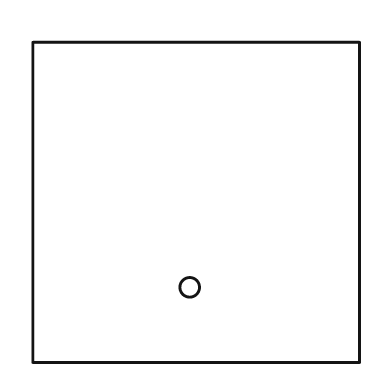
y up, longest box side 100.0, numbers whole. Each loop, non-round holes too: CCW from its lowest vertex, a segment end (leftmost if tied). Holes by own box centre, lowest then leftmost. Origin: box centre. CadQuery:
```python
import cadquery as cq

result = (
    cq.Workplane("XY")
    .moveTo(-50.0, -49.0)
    .lineTo(50.0, -49.0)
    .lineTo(50.0, 49.0)
    .lineTo(-50.0, 49.0)
    .close()
    .moveTo(-2.0, -26.0)
    .circle(3.0)
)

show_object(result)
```